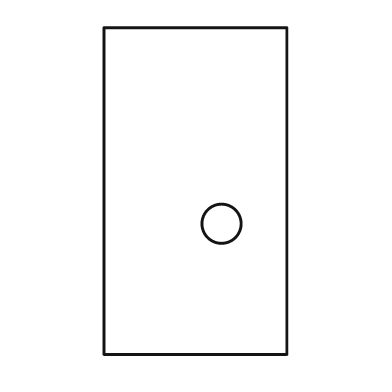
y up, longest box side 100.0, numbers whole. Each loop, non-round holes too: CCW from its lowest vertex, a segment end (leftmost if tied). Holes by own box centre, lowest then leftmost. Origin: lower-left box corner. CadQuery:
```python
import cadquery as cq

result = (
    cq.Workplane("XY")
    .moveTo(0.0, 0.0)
    .lineTo(56.0, 0.0)
    .lineTo(56.0, 100.0)
    .lineTo(0.0, 100.0)
    .close()
    .moveTo(36.0, 40.0)
    .circle(6.0)
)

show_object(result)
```